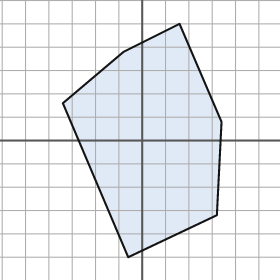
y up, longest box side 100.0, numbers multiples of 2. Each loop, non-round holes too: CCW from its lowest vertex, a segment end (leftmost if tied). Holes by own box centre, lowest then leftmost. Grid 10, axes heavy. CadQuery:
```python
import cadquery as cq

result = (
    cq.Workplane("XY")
    .moveTo(-6.0, -50.0)
    .lineTo(32.0, -32.0)
    .lineTo(34.0, 8.0)
    .lineTo(16.0, 50.0)
    .lineTo(-8.0, 38.0)
    .lineTo(-34.0, 16.0)
    .close()
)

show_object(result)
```